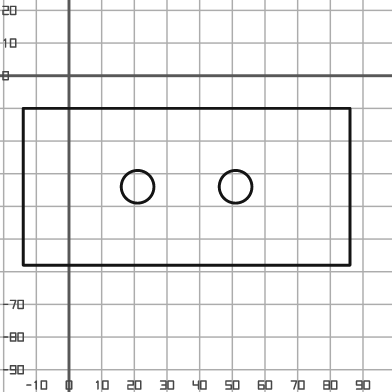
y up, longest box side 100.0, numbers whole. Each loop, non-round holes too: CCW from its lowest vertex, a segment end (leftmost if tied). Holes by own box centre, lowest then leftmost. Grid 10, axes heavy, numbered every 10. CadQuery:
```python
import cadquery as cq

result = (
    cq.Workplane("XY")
    .moveTo(-14.0, -58.0)
    .lineTo(86.0, -58.0)
    .lineTo(86.0, -10.0)
    .lineTo(-14.0, -10.0)
    .close()
    .moveTo(21.0, -34.0)
    .circle(5.0)
    .moveTo(51.0, -34.0)
    .circle(5.0)
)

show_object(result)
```